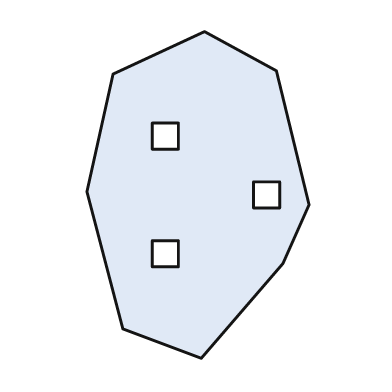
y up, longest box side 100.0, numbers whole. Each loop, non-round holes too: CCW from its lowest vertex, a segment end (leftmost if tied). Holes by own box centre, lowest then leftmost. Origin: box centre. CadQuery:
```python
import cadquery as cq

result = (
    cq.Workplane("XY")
    .moveTo(1.0, -50.0)
    .lineTo(26.0, -21.0)
    .lineTo(34.0, -3.0)
    .lineTo(24.0, 38.0)
    .lineTo(2.0, 50.0)
    .lineTo(-26.0, 37.0)
    .lineTo(-34.0, 1.0)
    .lineTo(-23.0, -41.0)
    .close()
    .moveTo(-14.0, -22.0)
    .lineTo(-6.0, -22.0)
    .lineTo(-6.0, -14.0)
    .lineTo(-14.0, -14.0)
    .close()
    .moveTo(17.0, -4.0)
    .lineTo(25.0, -4.0)
    .lineTo(25.0, 4.0)
    .lineTo(17.0, 4.0)
    .close()
    .moveTo(-14.0, 14.0)
    .lineTo(-6.0, 14.0)
    .lineTo(-6.0, 22.0)
    .lineTo(-14.0, 22.0)
    .close()
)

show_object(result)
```